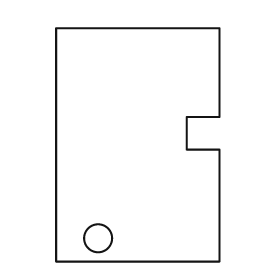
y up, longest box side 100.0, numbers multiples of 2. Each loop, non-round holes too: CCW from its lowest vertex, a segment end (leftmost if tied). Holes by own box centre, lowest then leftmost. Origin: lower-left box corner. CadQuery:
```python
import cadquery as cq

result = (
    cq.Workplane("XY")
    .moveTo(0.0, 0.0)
    .lineTo(70.0, 0.0)
    .lineTo(70.0, 48.0)
    .lineTo(56.0, 48.0)
    .lineTo(56.0, 62.0)
    .lineTo(70.0, 62.0)
    .lineTo(70.0, 100.0)
    .lineTo(0.0, 100.0)
    .close()
    .moveTo(18.0, 10.0)
    .circle(6.0)
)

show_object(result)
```